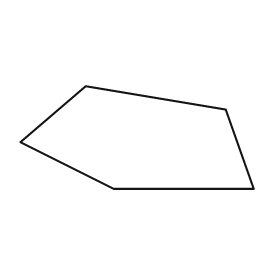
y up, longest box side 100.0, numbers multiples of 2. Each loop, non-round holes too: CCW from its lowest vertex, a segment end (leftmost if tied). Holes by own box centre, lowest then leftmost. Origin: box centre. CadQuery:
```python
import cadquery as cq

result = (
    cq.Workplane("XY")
    .moveTo(-10.0, -22.0)
    .lineTo(50.0, -22.0)
    .lineTo(38.0, 12.0)
    .lineTo(-22.0, 22.0)
    .lineTo(-50.0, -2.0)
    .close()
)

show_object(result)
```